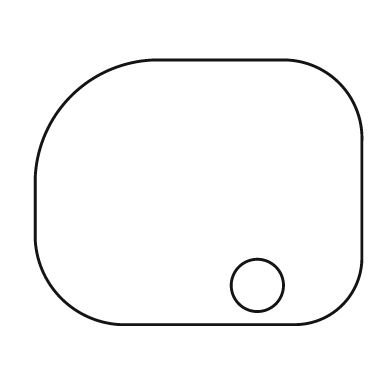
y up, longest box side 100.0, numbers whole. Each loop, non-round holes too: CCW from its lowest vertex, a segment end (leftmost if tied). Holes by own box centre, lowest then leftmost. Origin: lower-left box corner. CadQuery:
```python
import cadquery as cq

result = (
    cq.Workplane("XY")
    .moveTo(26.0, 0.0)
    .lineTo(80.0, 0.0)
    .threePointArc((94.0, 6.0), (100.0, 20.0))
    .lineTo(100.0, 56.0)
    .threePointArc((93.0, 74.0), (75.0, 81.0))
    .lineTo(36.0, 81.0)
    .threePointArc((11.0, 70.0), (0.0, 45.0))
    .lineTo(0.0, 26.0)
    .threePointArc((8.0, 8.0), (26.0, 0.0))
    .close()
    .moveTo(68.0, 12.0)
    .circle(8.0)
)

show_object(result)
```